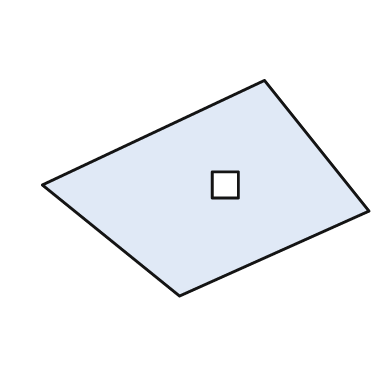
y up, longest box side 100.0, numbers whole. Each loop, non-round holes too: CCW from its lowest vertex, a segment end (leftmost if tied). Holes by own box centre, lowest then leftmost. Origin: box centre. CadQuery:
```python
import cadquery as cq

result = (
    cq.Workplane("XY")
    .moveTo(-8.0, -33.0)
    .lineTo(50.0, -7.0)
    .lineTo(18.0, 33.0)
    .lineTo(-50.0, 1.0)
    .close()
    .moveTo(2.0, -3.0)
    .lineTo(10.0, -3.0)
    .lineTo(10.0, 5.0)
    .lineTo(2.0, 5.0)
    .close()
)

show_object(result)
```